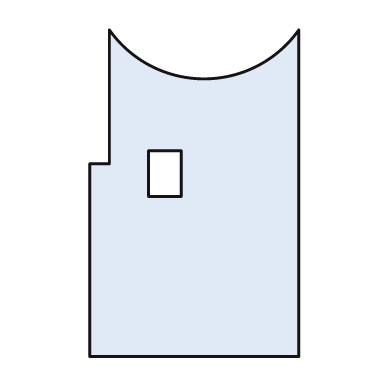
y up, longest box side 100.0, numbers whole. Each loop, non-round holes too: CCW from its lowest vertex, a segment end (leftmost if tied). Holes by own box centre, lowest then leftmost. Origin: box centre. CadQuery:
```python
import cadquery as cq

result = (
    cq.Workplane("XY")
    .moveTo(-32.0, -50.0)
    .lineTo(32.0, -50.0)
    .lineTo(32.0, 50.0)
    .threePointArc((3.0, 35.0), (-26.0, 50.0))
    .lineTo(-26.0, 9.0)
    .lineTo(-32.0, 9.0)
    .close()
    .moveTo(-14.0, -1.0)
    .lineTo(-4.0, -1.0)
    .lineTo(-4.0, 13.0)
    .lineTo(-14.0, 13.0)
    .close()
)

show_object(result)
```